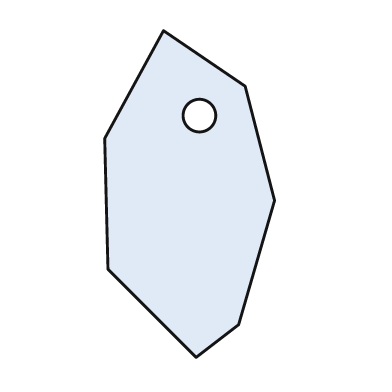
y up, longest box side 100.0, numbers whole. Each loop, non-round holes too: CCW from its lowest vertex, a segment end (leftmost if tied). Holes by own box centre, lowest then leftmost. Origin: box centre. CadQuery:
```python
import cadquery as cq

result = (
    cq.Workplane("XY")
    .moveTo(2.0, -50.0)
    .lineTo(15.0, -40.0)
    .lineTo(26.0, -2.0)
    .lineTo(17.0, 33.0)
    .lineTo(-8.0, 50.0)
    .lineTo(-26.0, 17.0)
    .lineTo(-25.0, -23.0)
    .close()
    .moveTo(3.0, 24.0)
    .circle(5.0)
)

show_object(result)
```